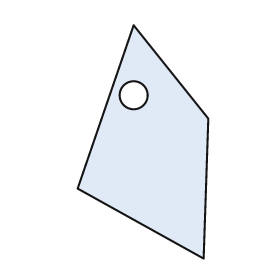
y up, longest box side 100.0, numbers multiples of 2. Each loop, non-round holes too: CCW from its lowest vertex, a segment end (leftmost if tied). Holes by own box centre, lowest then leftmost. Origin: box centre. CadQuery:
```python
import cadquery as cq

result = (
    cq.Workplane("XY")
    .moveTo(26.0, -50.0)
    .lineTo(28.0, 10.0)
    .lineTo(-4.0, 50.0)
    .lineTo(-28.0, -20.0)
    .close()
    .moveTo(-4.0, 20.0)
    .circle(6.0)
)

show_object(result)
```